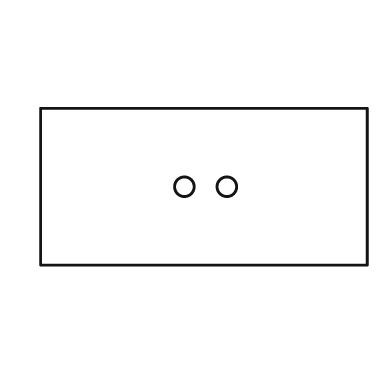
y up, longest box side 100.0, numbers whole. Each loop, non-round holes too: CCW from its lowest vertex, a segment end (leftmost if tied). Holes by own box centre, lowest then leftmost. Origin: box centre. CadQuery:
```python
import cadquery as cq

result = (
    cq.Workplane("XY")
    .moveTo(-50.0, -24.0)
    .lineTo(50.0, -24.0)
    .lineTo(50.0, 24.0)
    .lineTo(-50.0, 24.0)
    .close()
    .moveTo(-6.0, 0.0)
    .circle(3.0)
    .moveTo(7.0, 0.0)
    .circle(3.0)
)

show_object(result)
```